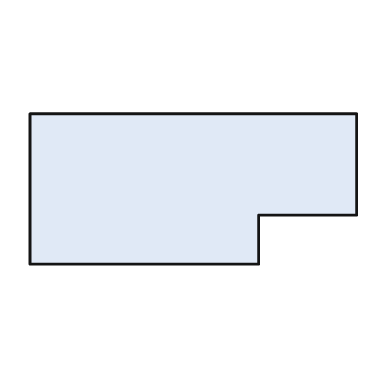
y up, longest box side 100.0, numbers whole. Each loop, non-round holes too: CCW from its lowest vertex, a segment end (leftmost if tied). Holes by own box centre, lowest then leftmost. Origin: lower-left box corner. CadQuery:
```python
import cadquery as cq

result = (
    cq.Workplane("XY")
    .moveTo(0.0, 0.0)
    .lineTo(70.0, 0.0)
    .lineTo(70.0, 15.0)
    .lineTo(100.0, 15.0)
    .lineTo(100.0, 46.0)
    .lineTo(0.0, 46.0)
    .close()
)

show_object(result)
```